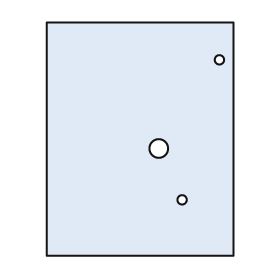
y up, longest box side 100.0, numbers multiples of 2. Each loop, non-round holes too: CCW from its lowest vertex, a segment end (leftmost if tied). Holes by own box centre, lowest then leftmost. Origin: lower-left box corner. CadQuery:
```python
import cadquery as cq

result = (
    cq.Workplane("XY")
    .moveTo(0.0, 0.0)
    .lineTo(80.0, 0.0)
    .lineTo(80.0, 100.0)
    .lineTo(0.0, 100.0)
    .close()
    .moveTo(58.0, 24.0)
    .circle(2.0)
    .moveTo(48.0, 46.0)
    .circle(4.0)
    .moveTo(74.0, 84.0)
    .circle(2.0)
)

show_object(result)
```